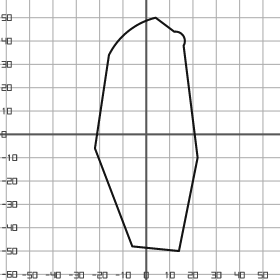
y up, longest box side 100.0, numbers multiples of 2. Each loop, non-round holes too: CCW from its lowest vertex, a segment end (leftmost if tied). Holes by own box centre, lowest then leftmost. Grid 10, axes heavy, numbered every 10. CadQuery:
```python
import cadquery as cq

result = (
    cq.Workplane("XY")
    .moveTo(14.0, -50.0)
    .lineTo(22.0, -10.0)
    .lineTo(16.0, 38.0)
    .threePointArc((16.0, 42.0), (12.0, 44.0))
    .lineTo(4.0, 50.0)
    .threePointArc((-8.0, 44.0), (-16.0, 34.0))
    .lineTo(-22.0, -6.0)
    .lineTo(-6.0, -48.0)
    .close()
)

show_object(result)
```